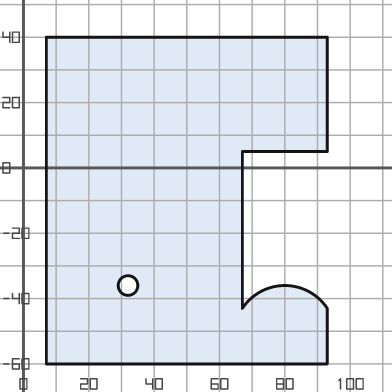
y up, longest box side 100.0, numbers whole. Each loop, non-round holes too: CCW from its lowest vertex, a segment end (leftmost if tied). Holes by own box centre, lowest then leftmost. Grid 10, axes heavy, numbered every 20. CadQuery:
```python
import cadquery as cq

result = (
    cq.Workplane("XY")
    .moveTo(7.0, -60.0)
    .lineTo(93.0, -60.0)
    .lineTo(93.0, -43.0)
    .threePointArc((80.0, -36.0), (67.0, -43.0))
    .lineTo(67.0, 5.0)
    .lineTo(93.0, 5.0)
    .lineTo(93.0, 40.0)
    .lineTo(7.0, 40.0)
    .close()
    .moveTo(32.0, -36.0)
    .circle(3.0)
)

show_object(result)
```